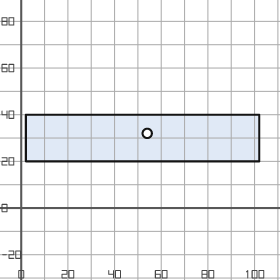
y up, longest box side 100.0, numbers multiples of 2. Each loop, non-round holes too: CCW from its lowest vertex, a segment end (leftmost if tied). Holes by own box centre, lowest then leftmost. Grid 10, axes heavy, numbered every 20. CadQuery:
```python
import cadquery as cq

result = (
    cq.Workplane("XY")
    .moveTo(2.0, 20.0)
    .lineTo(102.0, 20.0)
    .lineTo(102.0, 40.0)
    .lineTo(2.0, 40.0)
    .close()
    .moveTo(54.0, 32.0)
    .circle(2.0)
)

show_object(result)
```